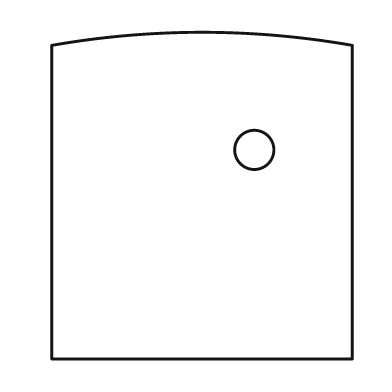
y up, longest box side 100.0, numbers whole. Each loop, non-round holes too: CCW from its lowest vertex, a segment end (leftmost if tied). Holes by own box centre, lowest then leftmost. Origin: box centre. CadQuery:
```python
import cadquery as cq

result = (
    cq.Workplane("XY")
    .moveTo(-46.0, -50.0)
    .lineTo(46.0, -50.0)
    .lineTo(46.0, 46.0)
    .threePointArc((0.0, 50.0), (-46.0, 46.0))
    .close()
    .moveTo(16.0, 14.0)
    .circle(6.0)
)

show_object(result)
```